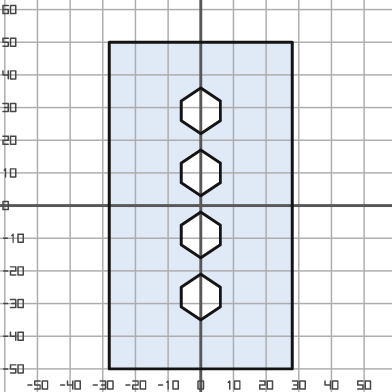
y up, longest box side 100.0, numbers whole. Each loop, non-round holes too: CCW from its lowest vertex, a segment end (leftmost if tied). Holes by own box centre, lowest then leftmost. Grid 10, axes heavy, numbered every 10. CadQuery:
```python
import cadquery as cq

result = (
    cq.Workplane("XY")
    .moveTo(-28.0, -50.0)
    .lineTo(28.0, -50.0)
    .lineTo(28.0, 50.0)
    .lineTo(-28.0, 50.0)
    .close()
    .moveTo(0.0, -35.0)
    .lineTo(6.0, -31.0)
    .lineTo(6.0, -25.0)
    .lineTo(0.0, -21.0)
    .lineTo(-6.0, -25.0)
    .lineTo(-6.0, -31.0)
    .close()
    .moveTo(0.0, -16.0)
    .lineTo(6.0, -12.0)
    .lineTo(6.0, -6.0)
    .lineTo(0.0, -2.0)
    .lineTo(-6.0, -6.0)
    .lineTo(-6.0, -12.0)
    .close()
    .moveTo(0.0, 3.0)
    .lineTo(6.0, 7.0)
    .lineTo(6.0, 13.0)
    .lineTo(0.0, 17.0)
    .lineTo(-6.0, 13.0)
    .lineTo(-6.0, 7.0)
    .close()
    .moveTo(0.0, 22.0)
    .lineTo(6.0, 26.0)
    .lineTo(6.0, 32.0)
    .lineTo(0.0, 36.0)
    .lineTo(-6.0, 32.0)
    .lineTo(-6.0, 26.0)
    .close()
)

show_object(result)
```